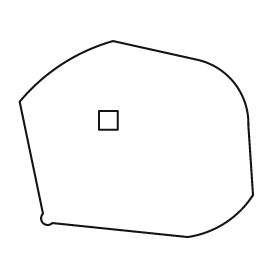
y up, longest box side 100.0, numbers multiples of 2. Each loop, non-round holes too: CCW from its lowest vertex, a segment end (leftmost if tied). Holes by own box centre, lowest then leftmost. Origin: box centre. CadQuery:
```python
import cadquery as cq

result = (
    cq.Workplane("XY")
    .moveTo(22.0, -42.0)
    .threePointArc((38.0, -36.0), (50.0, -24.0))
    .lineTo(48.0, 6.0)
    .threePointArc((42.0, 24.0), (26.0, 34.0))
    .lineTo(-10.0, 42.0)
    .threePointArc((-32.0, 32.0), (-50.0, 16.0))
    .lineTo(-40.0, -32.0)
    .threePointArc((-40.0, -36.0), (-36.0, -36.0))
    .close()
    .moveTo(-16.0, 4.0)
    .lineTo(-8.0, 4.0)
    .lineTo(-8.0, 12.0)
    .lineTo(-16.0, 12.0)
    .close()
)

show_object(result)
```